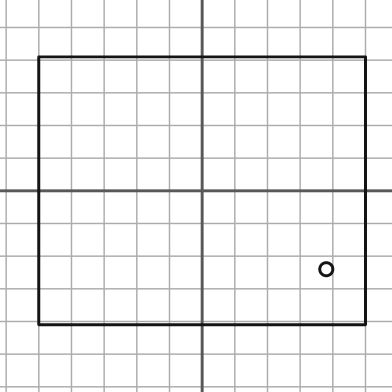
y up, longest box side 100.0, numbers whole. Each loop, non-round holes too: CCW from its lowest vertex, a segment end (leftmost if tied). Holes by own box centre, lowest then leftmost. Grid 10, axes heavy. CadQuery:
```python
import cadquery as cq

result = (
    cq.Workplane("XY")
    .moveTo(-50.0, -41.0)
    .lineTo(50.0, -41.0)
    .lineTo(50.0, 41.0)
    .lineTo(-50.0, 41.0)
    .close()
    .moveTo(38.0, -24.0)
    .circle(2.0)
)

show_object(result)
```